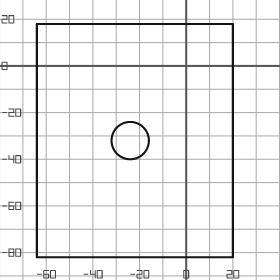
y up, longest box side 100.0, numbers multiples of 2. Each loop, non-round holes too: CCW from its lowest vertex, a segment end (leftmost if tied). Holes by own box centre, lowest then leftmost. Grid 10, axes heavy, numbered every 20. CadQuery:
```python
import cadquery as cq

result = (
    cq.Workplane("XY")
    .moveTo(-64.0, -82.0)
    .lineTo(20.0, -82.0)
    .lineTo(20.0, 18.0)
    .lineTo(-64.0, 18.0)
    .close()
    .moveTo(-24.0, -32.0)
    .circle(8.0)
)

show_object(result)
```